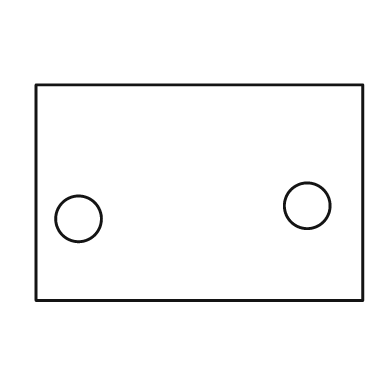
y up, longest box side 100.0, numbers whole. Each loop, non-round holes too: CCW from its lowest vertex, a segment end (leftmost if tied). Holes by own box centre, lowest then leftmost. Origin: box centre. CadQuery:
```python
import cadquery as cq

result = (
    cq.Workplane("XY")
    .moveTo(-50.0, -33.0)
    .lineTo(50.0, -33.0)
    .lineTo(50.0, 33.0)
    .lineTo(-50.0, 33.0)
    .close()
    .moveTo(-37.0, -8.0)
    .circle(7.0)
    .moveTo(33.0, -4.0)
    .circle(7.0)
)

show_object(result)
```